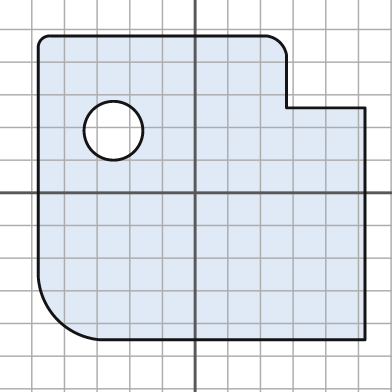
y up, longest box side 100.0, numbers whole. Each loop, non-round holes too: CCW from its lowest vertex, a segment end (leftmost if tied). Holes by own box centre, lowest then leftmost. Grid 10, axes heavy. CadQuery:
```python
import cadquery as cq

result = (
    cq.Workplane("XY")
    .moveTo(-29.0, -45.0)
    .lineTo(52.0, -45.0)
    .lineTo(52.0, 26.0)
    .lineTo(28.0, 26.0)
    .lineTo(28.0, 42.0)
    .threePointArc((26.0, 46.0), (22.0, 48.0))
    .lineTo(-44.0, 48.0)
    .threePointArc((-47.0, 47.0), (-48.0, 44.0))
    .lineTo(-48.0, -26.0)
    .threePointArc((-42.0, -39.0), (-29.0, -45.0))
    .close()
    .moveTo(-25.0, 19.0)
    .circle(9.0)
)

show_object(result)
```